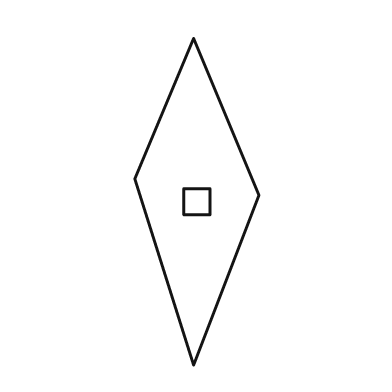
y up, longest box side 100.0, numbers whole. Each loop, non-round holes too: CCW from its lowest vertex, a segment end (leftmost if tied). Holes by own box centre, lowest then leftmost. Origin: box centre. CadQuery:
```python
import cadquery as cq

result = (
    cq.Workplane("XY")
    .moveTo(-1.0, -50.0)
    .lineTo(19.0, 2.0)
    .lineTo(-1.0, 50.0)
    .lineTo(-19.0, 7.0)
    .close()
    .moveTo(-4.0, -4.0)
    .lineTo(4.0, -4.0)
    .lineTo(4.0, 4.0)
    .lineTo(-4.0, 4.0)
    .close()
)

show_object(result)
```